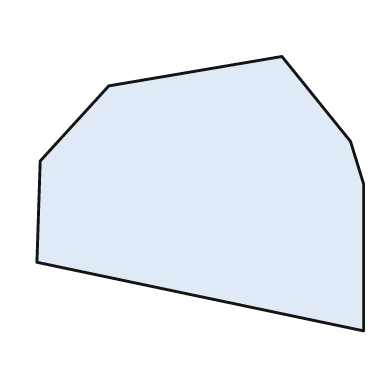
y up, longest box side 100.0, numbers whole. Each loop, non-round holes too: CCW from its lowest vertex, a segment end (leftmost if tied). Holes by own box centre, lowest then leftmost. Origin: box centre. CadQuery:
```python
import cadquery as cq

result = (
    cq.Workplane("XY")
    .moveTo(50.0, -42.0)
    .lineTo(50.0, 3.0)
    .lineTo(46.0, 16.0)
    .lineTo(25.0, 42.0)
    .lineTo(-28.0, 33.0)
    .lineTo(-49.0, 10.0)
    .lineTo(-50.0, -21.0)
    .close()
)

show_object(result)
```